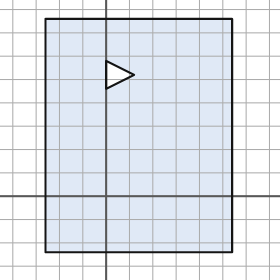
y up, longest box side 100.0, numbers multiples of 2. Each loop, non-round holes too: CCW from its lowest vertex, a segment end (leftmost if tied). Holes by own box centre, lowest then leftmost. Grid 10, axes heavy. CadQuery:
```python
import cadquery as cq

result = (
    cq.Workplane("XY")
    .moveTo(-26.0, -24.0)
    .lineTo(54.0, -24.0)
    .lineTo(54.0, 76.0)
    .lineTo(-26.0, 76.0)
    .close()
    .moveTo(0.0, 46.0)
    .lineTo(12.0, 52.0)
    .lineTo(0.0, 58.0)
    .close()
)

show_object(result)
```